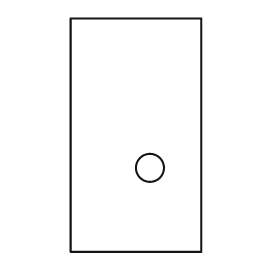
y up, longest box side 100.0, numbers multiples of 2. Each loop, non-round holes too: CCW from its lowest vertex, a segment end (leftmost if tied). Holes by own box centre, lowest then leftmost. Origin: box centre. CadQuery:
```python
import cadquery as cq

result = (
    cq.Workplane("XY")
    .moveTo(-28.0, -50.0)
    .lineTo(28.0, -50.0)
    .lineTo(28.0, 50.0)
    .lineTo(-28.0, 50.0)
    .close()
    .moveTo(6.0, -14.0)
    .circle(6.0)
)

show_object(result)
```